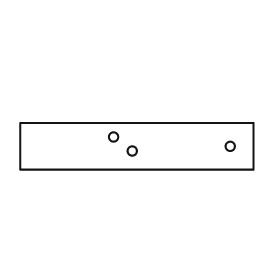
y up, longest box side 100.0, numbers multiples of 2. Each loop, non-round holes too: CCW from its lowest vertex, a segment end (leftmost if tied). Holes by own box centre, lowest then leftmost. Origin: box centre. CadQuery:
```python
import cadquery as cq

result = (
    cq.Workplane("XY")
    .moveTo(-50.0, -10.0)
    .lineTo(50.0, -10.0)
    .lineTo(50.0, 10.0)
    .lineTo(-50.0, 10.0)
    .close()
    .moveTo(-2.0, -2.0)
    .circle(2.0)
    .moveTo(40.0, 0.0)
    .circle(2.0)
    .moveTo(-10.0, 4.0)
    .circle(2.0)
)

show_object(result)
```